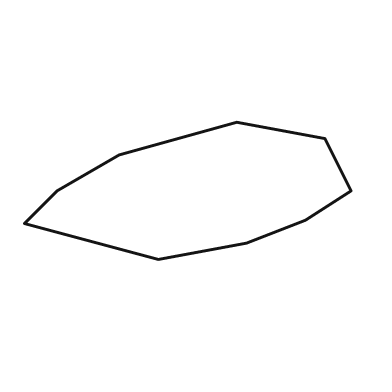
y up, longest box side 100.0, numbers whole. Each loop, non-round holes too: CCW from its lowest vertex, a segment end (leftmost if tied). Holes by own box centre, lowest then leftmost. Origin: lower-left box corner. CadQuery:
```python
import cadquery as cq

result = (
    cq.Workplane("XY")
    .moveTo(41.0, 0.0)
    .lineTo(68.0, 5.0)
    .lineTo(86.0, 12.0)
    .lineTo(100.0, 21.0)
    .lineTo(92.0, 37.0)
    .lineTo(65.0, 42.0)
    .lineTo(29.0, 32.0)
    .lineTo(10.0, 21.0)
    .lineTo(0.0, 11.0)
    .close()
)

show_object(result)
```